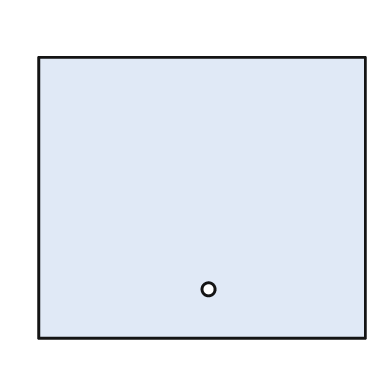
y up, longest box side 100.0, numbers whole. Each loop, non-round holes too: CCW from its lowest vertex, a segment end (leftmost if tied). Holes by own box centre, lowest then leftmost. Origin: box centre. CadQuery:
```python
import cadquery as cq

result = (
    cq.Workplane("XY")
    .moveTo(-50.0, -43.0)
    .lineTo(50.0, -43.0)
    .lineTo(50.0, 43.0)
    .lineTo(-50.0, 43.0)
    .close()
    .moveTo(2.0, -28.0)
    .circle(2.0)
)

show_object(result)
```